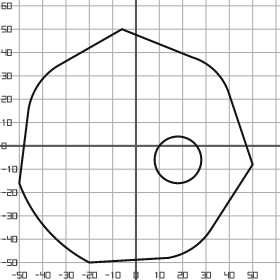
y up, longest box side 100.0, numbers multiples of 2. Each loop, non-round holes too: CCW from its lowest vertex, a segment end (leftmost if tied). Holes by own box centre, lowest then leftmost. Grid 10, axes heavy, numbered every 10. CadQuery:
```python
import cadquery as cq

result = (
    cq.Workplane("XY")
    .moveTo(-20.0, -50.0)
    .lineTo(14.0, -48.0)
    .threePointArc((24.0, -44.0), (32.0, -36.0))
    .lineTo(50.0, -8.0)
    .lineTo(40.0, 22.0)
    .threePointArc((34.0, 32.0), (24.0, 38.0))
    .lineTo(-6.0, 50.0)
    .lineTo(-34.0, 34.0)
    .threePointArc((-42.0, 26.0), (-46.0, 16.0))
    .lineTo(-50.0, -16.0)
    .threePointArc((-38.0, -36.0), (-20.0, -50.0))
    .close()
    .moveTo(18.0, -6.0)
    .circle(10.0)
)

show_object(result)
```